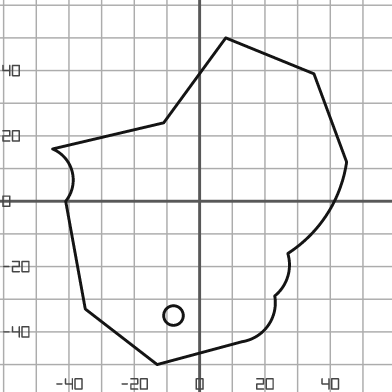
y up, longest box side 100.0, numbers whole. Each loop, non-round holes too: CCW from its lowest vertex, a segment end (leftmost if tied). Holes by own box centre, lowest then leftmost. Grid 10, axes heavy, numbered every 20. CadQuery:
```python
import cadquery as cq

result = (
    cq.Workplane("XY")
    .moveTo(-13.0, -50.0)
    .lineTo(13.0, -43.0)
    .threePointArc((21.0, -38.0), (23.0, -29.0))
    .threePointArc((27.0, -23.0), (27.0, -16.0))
    .threePointArc((39.0, -4.0), (45.0, 12.0))
    .lineTo(35.0, 39.0)
    .lineTo(8.0, 50.0)
    .lineTo(-11.0, 24.0)
    .lineTo(-45.0, 16.0)
    .threePointArc((-39.0, 9.0), (-41.0, 0.0))
    .lineTo(-35.0, -33.0)
    .close()
    .moveTo(-8.0, -35.0)
    .circle(3.0)
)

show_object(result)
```